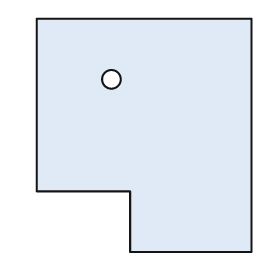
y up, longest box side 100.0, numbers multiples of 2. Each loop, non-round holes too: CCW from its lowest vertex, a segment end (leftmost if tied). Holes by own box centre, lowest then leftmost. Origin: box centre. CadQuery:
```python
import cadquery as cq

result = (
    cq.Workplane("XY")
    .moveTo(-6.0, -50.0)
    .lineTo(46.0, -50.0)
    .lineTo(46.0, 50.0)
    .lineTo(-46.0, 50.0)
    .lineTo(-46.0, -24.0)
    .lineTo(-6.0, -24.0)
    .close()
    .moveTo(-14.0, 24.0)
    .circle(4.0)
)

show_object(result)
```